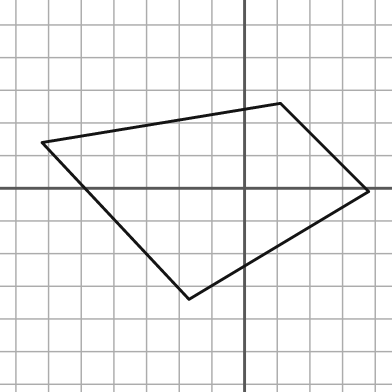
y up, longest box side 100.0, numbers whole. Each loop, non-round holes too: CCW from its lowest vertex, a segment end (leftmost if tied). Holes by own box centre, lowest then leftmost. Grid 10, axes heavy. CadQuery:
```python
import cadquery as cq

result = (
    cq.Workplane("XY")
    .moveTo(-17.0, -34.0)
    .lineTo(38.0, -1.0)
    .lineTo(11.0, 26.0)
    .lineTo(-62.0, 14.0)
    .close()
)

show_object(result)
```